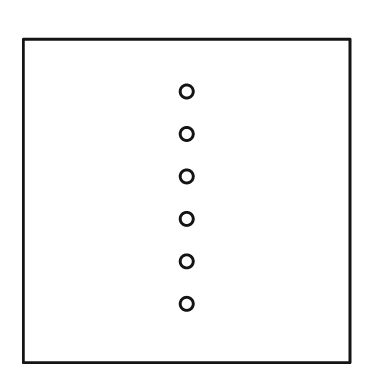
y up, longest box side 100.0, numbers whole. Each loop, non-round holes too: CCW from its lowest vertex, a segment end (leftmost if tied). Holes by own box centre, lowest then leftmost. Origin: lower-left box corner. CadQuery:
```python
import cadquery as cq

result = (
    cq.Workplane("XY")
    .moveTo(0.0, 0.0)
    .lineTo(100.0, 0.0)
    .lineTo(100.0, 99.0)
    .lineTo(0.0, 99.0)
    .close()
    .moveTo(50.0, 18.0)
    .circle(2.0)
    .moveTo(50.0, 31.0)
    .circle(2.0)
    .moveTo(50.0, 44.0)
    .circle(2.0)
    .moveTo(50.0, 57.0)
    .circle(2.0)
    .moveTo(50.0, 70.0)
    .circle(2.0)
    .moveTo(50.0, 83.0)
    .circle(2.0)
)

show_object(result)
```